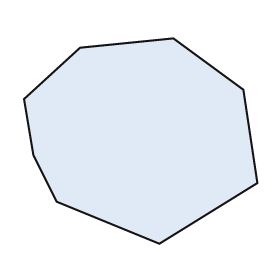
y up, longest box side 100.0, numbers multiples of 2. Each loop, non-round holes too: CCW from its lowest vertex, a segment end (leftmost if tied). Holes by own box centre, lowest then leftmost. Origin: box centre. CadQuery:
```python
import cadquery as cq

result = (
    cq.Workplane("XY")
    .moveTo(8.0, -44.0)
    .lineTo(50.0, -18.0)
    .lineTo(44.0, 22.0)
    .lineTo(14.0, 44.0)
    .lineTo(-26.0, 40.0)
    .lineTo(-50.0, 18.0)
    .lineTo(-46.0, -6.0)
    .lineTo(-36.0, -26.0)
    .close()
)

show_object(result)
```